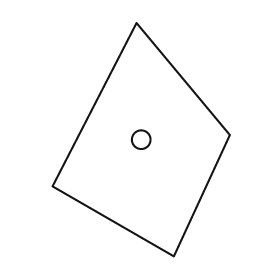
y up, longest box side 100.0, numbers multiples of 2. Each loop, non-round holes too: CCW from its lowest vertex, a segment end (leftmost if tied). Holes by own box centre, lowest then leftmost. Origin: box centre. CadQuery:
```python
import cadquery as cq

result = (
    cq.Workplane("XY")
    .moveTo(14.0, -50.0)
    .lineTo(38.0, 2.0)
    .lineTo(-2.0, 50.0)
    .lineTo(-38.0, -20.0)
    .close()
    .moveTo(0.0, 0.0)
    .circle(4.0)
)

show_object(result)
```